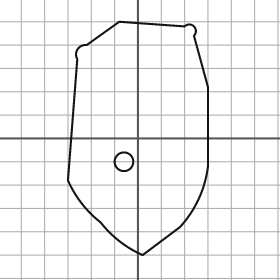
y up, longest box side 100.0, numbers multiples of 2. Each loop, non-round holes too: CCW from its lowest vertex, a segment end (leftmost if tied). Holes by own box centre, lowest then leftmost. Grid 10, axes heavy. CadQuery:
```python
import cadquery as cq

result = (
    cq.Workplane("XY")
    .moveTo(2.0, -50.0)
    .lineTo(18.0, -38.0)
    .threePointArc((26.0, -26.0), (30.0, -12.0))
    .lineTo(30.0, 22.0)
    .lineTo(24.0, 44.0)
    .threePointArc((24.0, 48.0), (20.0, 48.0))
    .lineTo(-8.0, 50.0)
    .lineTo(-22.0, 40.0)
    .threePointArc((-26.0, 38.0), (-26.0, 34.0))
    .lineTo(-30.0, -18.0)
    .threePointArc((-24.0, -28.0), (-16.0, -36.0))
    .threePointArc((-8.0, -44.0), (2.0, -50.0))
    .close()
    .moveTo(-6.0, -10.0)
    .circle(4.0)
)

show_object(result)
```